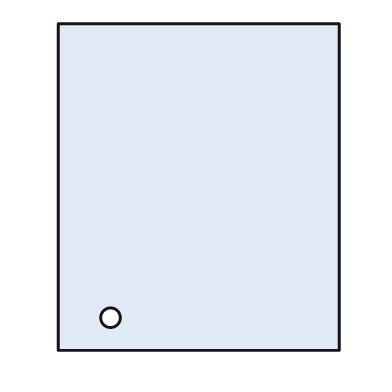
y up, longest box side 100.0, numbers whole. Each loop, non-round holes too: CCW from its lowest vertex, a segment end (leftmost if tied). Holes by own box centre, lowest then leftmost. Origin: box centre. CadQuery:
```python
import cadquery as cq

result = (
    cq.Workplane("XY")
    .moveTo(-43.0, -50.0)
    .lineTo(43.0, -50.0)
    .lineTo(43.0, 50.0)
    .lineTo(-43.0, 50.0)
    .close()
    .moveTo(-27.0, -40.0)
    .circle(3.0)
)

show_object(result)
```